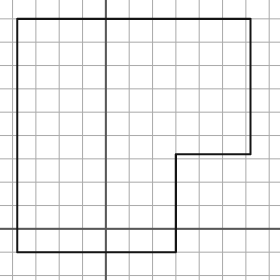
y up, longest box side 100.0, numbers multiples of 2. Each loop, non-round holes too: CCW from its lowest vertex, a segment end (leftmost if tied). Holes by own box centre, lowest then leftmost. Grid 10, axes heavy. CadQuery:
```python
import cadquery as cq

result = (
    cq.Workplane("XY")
    .moveTo(-38.0, -10.0)
    .lineTo(30.0, -10.0)
    .lineTo(30.0, 32.0)
    .lineTo(62.0, 32.0)
    .lineTo(62.0, 90.0)
    .lineTo(-38.0, 90.0)
    .close()
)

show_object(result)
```